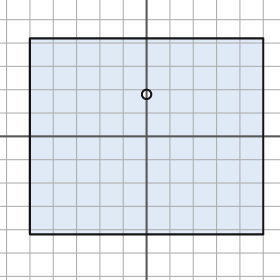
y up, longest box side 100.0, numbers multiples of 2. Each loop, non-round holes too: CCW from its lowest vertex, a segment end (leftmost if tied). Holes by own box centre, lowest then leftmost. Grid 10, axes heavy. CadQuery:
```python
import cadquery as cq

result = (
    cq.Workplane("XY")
    .moveTo(-50.0, -42.0)
    .lineTo(50.0, -42.0)
    .lineTo(50.0, 42.0)
    .lineTo(-50.0, 42.0)
    .close()
    .moveTo(0.0, 18.0)
    .circle(2.0)
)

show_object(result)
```